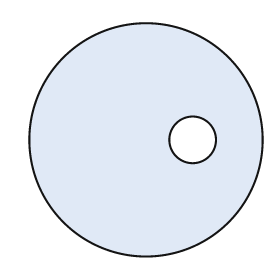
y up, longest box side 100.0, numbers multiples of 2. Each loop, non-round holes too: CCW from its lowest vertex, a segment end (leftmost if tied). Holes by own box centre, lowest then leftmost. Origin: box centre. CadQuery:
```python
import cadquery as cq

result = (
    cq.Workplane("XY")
    .moveTo(0.0, 0.0)
    .circle(50.0)
    .moveTo(20.0, 0.0)
    .circle(10.0)
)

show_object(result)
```